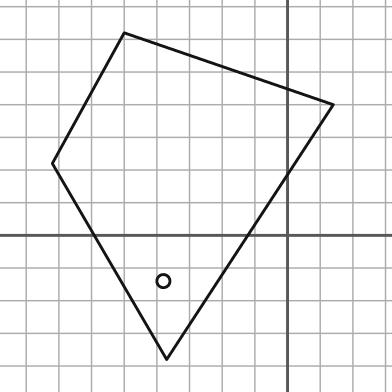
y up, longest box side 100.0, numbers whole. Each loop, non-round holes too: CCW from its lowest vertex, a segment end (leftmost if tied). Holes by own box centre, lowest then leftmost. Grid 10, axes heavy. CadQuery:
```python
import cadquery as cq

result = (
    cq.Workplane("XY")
    .moveTo(-37.0, -38.0)
    .lineTo(14.0, 40.0)
    .lineTo(-50.0, 62.0)
    .lineTo(-72.0, 22.0)
    .close()
    .moveTo(-38.0, -14.0)
    .circle(2.0)
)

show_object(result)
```